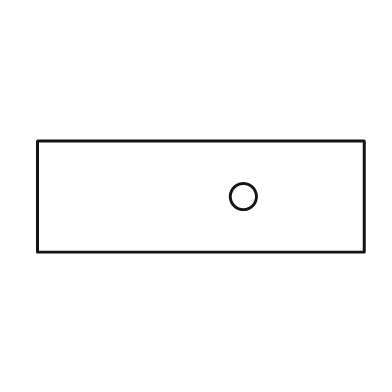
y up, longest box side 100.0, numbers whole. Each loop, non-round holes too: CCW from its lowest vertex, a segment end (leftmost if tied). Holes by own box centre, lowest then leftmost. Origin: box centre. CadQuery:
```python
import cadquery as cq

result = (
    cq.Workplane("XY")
    .moveTo(-50.0, -17.0)
    .lineTo(50.0, -17.0)
    .lineTo(50.0, 17.0)
    .lineTo(-50.0, 17.0)
    .close()
    .moveTo(13.0, 0.0)
    .circle(4.0)
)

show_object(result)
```